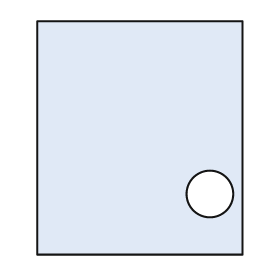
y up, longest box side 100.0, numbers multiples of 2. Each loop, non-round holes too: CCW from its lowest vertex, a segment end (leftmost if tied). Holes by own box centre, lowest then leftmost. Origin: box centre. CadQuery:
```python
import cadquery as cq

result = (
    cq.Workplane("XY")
    .moveTo(-44.0, -50.0)
    .lineTo(44.0, -50.0)
    .lineTo(44.0, 50.0)
    .lineTo(-44.0, 50.0)
    .close()
    .moveTo(30.0, -24.0)
    .circle(10.0)
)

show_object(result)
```